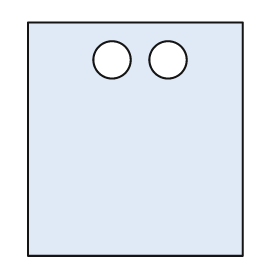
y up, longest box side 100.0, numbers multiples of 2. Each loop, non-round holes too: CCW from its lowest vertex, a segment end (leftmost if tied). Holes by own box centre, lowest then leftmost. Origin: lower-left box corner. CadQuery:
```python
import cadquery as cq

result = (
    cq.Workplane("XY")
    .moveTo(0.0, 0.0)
    .lineTo(92.0, 0.0)
    .lineTo(92.0, 100.0)
    .lineTo(0.0, 100.0)
    .close()
    .moveTo(36.0, 84.0)
    .circle(8.0)
    .moveTo(60.0, 84.0)
    .circle(8.0)
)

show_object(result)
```